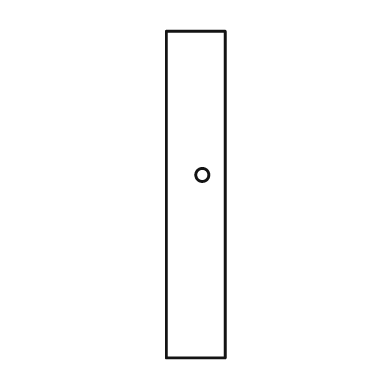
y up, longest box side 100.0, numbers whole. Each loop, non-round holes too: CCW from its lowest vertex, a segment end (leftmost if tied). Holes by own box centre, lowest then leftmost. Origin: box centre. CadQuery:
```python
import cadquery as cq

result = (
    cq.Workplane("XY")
    .moveTo(-9.0, -50.0)
    .lineTo(9.0, -50.0)
    .lineTo(9.0, 50.0)
    .lineTo(-9.0, 50.0)
    .close()
    .moveTo(2.0, 6.0)
    .circle(2.0)
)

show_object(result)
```